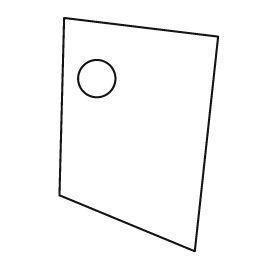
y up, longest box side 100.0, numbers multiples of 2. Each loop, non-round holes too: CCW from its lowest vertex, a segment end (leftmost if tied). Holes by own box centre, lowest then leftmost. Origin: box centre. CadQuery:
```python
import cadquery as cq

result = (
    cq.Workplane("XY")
    .moveTo(24.0, -50.0)
    .lineTo(34.0, 42.0)
    .lineTo(-32.0, 50.0)
    .lineTo(-34.0, -26.0)
    .close()
    .moveTo(-18.0, 24.0)
    .circle(8.0)
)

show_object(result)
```